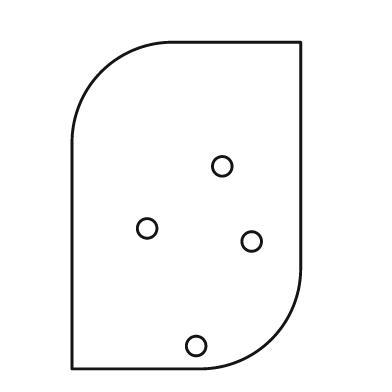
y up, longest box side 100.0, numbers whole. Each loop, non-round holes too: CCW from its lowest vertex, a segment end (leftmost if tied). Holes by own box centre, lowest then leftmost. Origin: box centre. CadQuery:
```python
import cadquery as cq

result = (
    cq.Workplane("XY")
    .moveTo(-35.0, -50.0)
    .lineTo(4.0, -50.0)
    .threePointArc((26.0, -41.0), (35.0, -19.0))
    .lineTo(35.0, 50.0)
    .lineTo(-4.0, 50.0)
    .threePointArc((-26.0, 41.0), (-35.0, 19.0))
    .close()
    .moveTo(3.0, -43.0)
    .circle(3.0)
    .moveTo(20.0, -11.0)
    .circle(3.0)
    .moveTo(-12.0, -7.0)
    .circle(3.0)
    .moveTo(11.0, 12.0)
    .circle(3.0)
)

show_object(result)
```